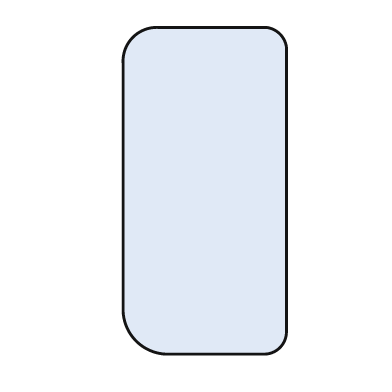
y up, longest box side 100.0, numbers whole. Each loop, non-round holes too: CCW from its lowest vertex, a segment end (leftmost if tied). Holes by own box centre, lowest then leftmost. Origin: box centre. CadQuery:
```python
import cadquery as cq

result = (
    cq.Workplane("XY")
    .moveTo(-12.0, -50.0)
    .lineTo(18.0, -50.0)
    .threePointArc((23.0, -48.0), (25.0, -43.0))
    .lineTo(25.0, 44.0)
    .threePointArc((23.0, 48.0), (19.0, 50.0))
    .lineTo(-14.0, 50.0)
    .threePointArc((-22.0, 47.0), (-25.0, 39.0))
    .lineTo(-25.0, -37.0)
    .threePointArc((-21.0, -46.0), (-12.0, -50.0))
    .close()
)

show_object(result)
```